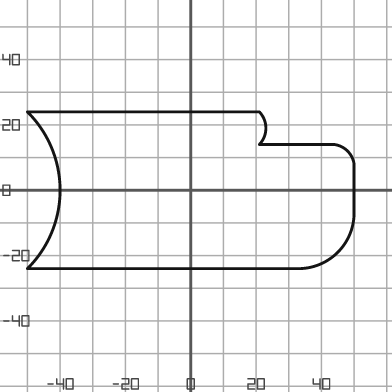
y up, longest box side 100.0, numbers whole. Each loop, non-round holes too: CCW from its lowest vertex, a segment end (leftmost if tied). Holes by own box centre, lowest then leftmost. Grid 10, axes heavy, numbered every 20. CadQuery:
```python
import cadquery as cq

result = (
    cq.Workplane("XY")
    .moveTo(-50.0, -24.0)
    .lineTo(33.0, -24.0)
    .threePointArc((45.0, -19.0), (50.0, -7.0))
    .lineTo(50.0, 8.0)
    .threePointArc((48.0, 12.0), (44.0, 14.0))
    .lineTo(21.0, 14.0)
    .threePointArc((23.0, 19.0), (21.0, 24.0))
    .lineTo(-50.0, 24.0)
    .threePointArc((-40.0, 0.0), (-50.0, -24.0))
    .close()
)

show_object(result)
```